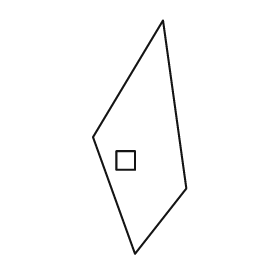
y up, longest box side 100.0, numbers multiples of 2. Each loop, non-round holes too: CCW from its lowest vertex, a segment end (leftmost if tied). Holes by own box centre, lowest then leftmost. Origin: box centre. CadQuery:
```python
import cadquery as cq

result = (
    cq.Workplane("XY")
    .moveTo(-2.0, -50.0)
    .lineTo(20.0, -22.0)
    .lineTo(10.0, 50.0)
    .lineTo(-20.0, 0.0)
    .close()
    .moveTo(-10.0, -14.0)
    .lineTo(-2.0, -14.0)
    .lineTo(-2.0, -6.0)
    .lineTo(-10.0, -6.0)
    .close()
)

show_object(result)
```